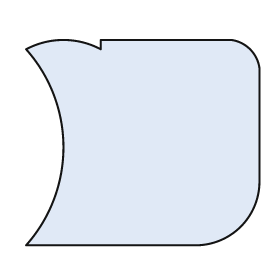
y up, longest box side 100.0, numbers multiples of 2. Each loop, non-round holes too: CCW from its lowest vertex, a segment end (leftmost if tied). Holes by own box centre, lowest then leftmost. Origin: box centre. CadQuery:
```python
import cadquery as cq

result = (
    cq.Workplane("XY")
    .moveTo(-50.0, -44.0)
    .lineTo(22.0, -44.0)
    .threePointArc((42.0, -36.0), (50.0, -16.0))
    .lineTo(50.0, 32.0)
    .threePointArc((46.0, 40.0), (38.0, 44.0))
    .lineTo(-18.0, 44.0)
    .lineTo(-18.0, 40.0)
    .threePointArc((-34.0, 44.0), (-50.0, 40.0))
    .threePointArc((-34.0, -2.0), (-50.0, -44.0))
    .close()
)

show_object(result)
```